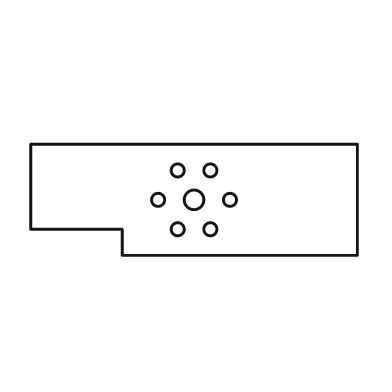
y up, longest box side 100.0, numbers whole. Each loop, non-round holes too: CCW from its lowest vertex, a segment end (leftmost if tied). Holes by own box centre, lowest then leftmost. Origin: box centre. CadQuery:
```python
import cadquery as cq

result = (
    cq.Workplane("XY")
    .moveTo(-22.0, -17.0)
    .lineTo(50.0, -17.0)
    .lineTo(50.0, 17.0)
    .lineTo(-50.0, 17.0)
    .lineTo(-50.0, -9.0)
    .lineTo(-22.0, -9.0)
    .close()
    .moveTo(-5.0, -9.0)
    .circle(2.0)
    .moveTo(5.0, -9.0)
    .circle(2.0)
    .moveTo(-11.0, 0.0)
    .circle(2.0)
    .moveTo(0.0, 0.0)
    .circle(3.0)
    .moveTo(11.0, 0.0)
    .circle(2.0)
    .moveTo(-5.0, 9.0)
    .circle(2.0)
    .moveTo(5.0, 9.0)
    .circle(2.0)
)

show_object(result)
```